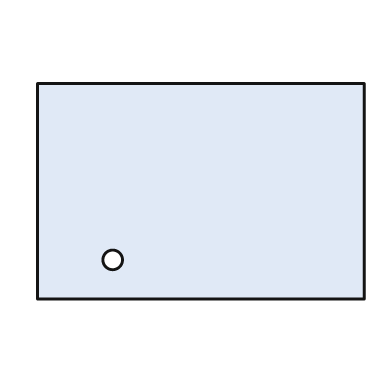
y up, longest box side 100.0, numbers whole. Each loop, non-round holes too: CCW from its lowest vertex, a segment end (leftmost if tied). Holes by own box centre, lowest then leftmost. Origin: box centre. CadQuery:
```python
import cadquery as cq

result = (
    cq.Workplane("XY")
    .moveTo(-50.0, -33.0)
    .lineTo(50.0, -33.0)
    .lineTo(50.0, 33.0)
    .lineTo(-50.0, 33.0)
    .close()
    .moveTo(-27.0, -21.0)
    .circle(3.0)
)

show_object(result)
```